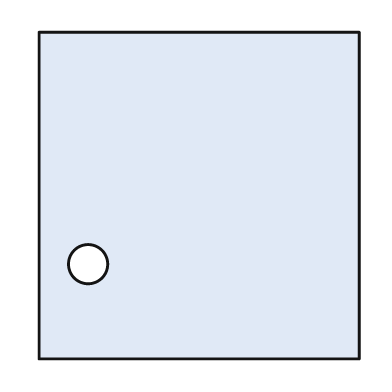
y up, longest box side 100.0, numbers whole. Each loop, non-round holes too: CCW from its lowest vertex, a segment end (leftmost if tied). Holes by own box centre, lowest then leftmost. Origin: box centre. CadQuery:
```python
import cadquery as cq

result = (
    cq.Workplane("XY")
    .moveTo(-49.0, -50.0)
    .lineTo(49.0, -50.0)
    .lineTo(49.0, 50.0)
    .lineTo(-49.0, 50.0)
    .close()
    .moveTo(-34.0, -21.0)
    .circle(6.0)
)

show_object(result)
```